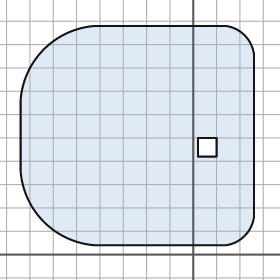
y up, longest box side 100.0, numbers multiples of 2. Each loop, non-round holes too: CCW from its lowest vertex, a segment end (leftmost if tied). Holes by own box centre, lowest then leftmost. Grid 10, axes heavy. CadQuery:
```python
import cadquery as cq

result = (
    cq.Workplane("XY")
    .moveTo(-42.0, 4.0)
    .lineTo(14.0, 4.0)
    .threePointArc((22.0, 8.0), (26.0, 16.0))
    .lineTo(26.0, 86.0)
    .threePointArc((22.0, 94.0), (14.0, 98.0))
    .lineTo(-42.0, 98.0)
    .threePointArc((-64.0, 88.0), (-74.0, 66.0))
    .lineTo(-74.0, 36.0)
    .threePointArc((-64.0, 14.0), (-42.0, 4.0))
    .close()
    .moveTo(2.0, 42.0)
    .lineTo(10.0, 42.0)
    .lineTo(10.0, 50.0)
    .lineTo(2.0, 50.0)
    .close()
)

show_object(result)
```